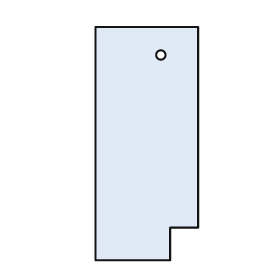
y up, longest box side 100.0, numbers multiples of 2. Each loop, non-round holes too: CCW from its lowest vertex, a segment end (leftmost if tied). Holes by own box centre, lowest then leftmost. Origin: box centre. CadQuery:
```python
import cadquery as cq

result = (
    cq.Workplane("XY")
    .moveTo(-22.0, -50.0)
    .lineTo(10.0, -50.0)
    .lineTo(10.0, -36.0)
    .lineTo(22.0, -36.0)
    .lineTo(22.0, 50.0)
    .lineTo(-22.0, 50.0)
    .close()
    .moveTo(6.0, 38.0)
    .circle(2.0)
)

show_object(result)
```